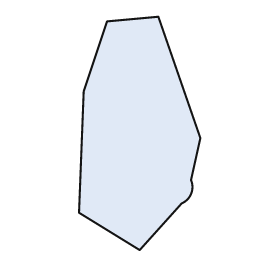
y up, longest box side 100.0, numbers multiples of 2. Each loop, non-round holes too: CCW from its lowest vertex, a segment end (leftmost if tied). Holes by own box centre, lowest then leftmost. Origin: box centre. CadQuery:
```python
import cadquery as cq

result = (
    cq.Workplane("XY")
    .moveTo(0.0, -50.0)
    .lineTo(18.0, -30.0)
    .threePointArc((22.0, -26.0), (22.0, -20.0))
    .lineTo(26.0, -2.0)
    .lineTo(8.0, 50.0)
    .lineTo(-14.0, 48.0)
    .lineTo(-24.0, 18.0)
    .lineTo(-26.0, -34.0)
    .close()
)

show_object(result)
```